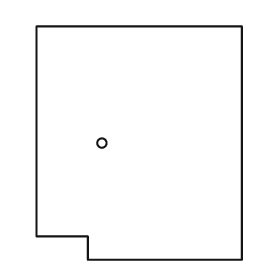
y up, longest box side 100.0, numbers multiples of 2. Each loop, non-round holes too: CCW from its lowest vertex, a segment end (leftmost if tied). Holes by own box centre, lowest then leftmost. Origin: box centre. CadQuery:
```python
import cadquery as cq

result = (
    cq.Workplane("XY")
    .moveTo(-22.0, -50.0)
    .lineTo(44.0, -50.0)
    .lineTo(44.0, 50.0)
    .lineTo(-44.0, 50.0)
    .lineTo(-44.0, -40.0)
    .lineTo(-22.0, -40.0)
    .close()
    .moveTo(-16.0, 0.0)
    .circle(2.0)
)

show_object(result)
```